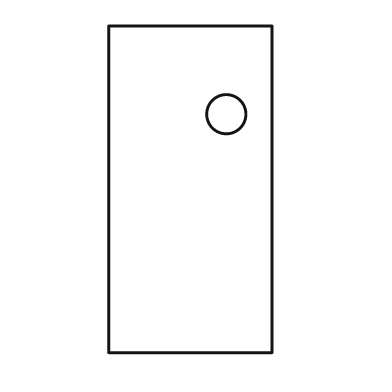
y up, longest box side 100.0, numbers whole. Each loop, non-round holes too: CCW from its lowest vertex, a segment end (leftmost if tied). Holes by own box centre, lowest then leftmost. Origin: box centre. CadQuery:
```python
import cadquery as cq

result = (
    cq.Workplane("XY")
    .moveTo(-25.0, -50.0)
    .lineTo(25.0, -50.0)
    .lineTo(25.0, 50.0)
    .lineTo(-25.0, 50.0)
    .close()
    .moveTo(11.0, 23.0)
    .circle(6.0)
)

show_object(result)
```